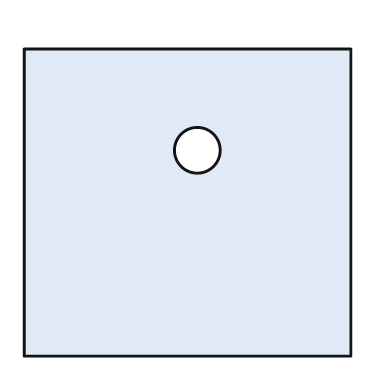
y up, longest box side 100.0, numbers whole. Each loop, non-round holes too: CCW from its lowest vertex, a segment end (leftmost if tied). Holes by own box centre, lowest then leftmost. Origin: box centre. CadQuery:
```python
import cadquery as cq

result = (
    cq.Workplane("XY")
    .moveTo(-50.0, -47.0)
    .lineTo(50.0, -47.0)
    .lineTo(50.0, 47.0)
    .lineTo(-50.0, 47.0)
    .close()
    .moveTo(3.0, 16.0)
    .circle(7.0)
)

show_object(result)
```